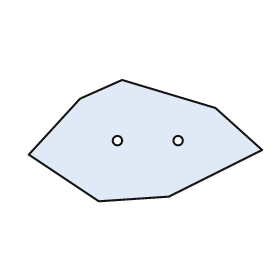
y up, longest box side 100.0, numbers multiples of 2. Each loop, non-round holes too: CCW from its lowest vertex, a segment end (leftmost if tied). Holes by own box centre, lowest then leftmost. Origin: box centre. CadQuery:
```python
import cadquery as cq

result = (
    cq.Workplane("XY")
    .moveTo(-20.0, -26.0)
    .lineTo(10.0, -24.0)
    .lineTo(50.0, -4.0)
    .lineTo(30.0, 14.0)
    .lineTo(-10.0, 26.0)
    .lineTo(-28.0, 18.0)
    .lineTo(-50.0, -6.0)
    .close()
    .moveTo(-12.0, 0.0)
    .circle(2.0)
    .moveTo(14.0, 0.0)
    .circle(2.0)
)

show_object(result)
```